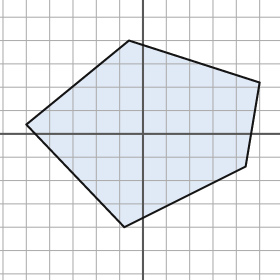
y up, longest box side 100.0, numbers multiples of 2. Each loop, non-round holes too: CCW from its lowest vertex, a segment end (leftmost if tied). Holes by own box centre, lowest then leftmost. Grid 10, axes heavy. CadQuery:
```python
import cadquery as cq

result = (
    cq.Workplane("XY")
    .moveTo(-8.0, -40.0)
    .lineTo(44.0, -14.0)
    .lineTo(50.0, 22.0)
    .lineTo(-6.0, 40.0)
    .lineTo(-50.0, 4.0)
    .close()
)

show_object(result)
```